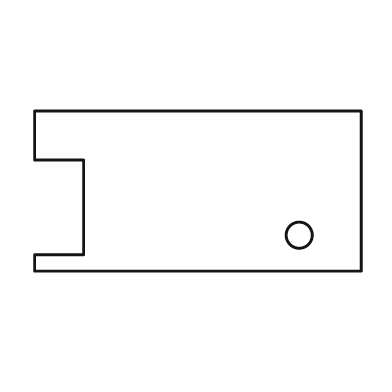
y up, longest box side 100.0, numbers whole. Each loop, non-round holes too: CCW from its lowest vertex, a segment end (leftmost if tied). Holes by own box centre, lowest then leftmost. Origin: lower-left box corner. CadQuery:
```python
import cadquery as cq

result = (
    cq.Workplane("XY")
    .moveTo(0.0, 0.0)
    .lineTo(100.0, 0.0)
    .lineTo(100.0, 49.0)
    .lineTo(0.0, 49.0)
    .lineTo(0.0, 34.0)
    .lineTo(15.0, 34.0)
    .lineTo(15.0, 5.0)
    .lineTo(0.0, 5.0)
    .close()
    .moveTo(81.0, 11.0)
    .circle(4.0)
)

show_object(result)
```